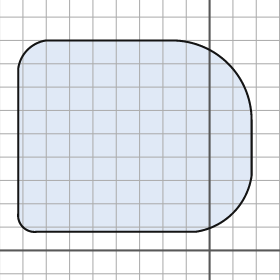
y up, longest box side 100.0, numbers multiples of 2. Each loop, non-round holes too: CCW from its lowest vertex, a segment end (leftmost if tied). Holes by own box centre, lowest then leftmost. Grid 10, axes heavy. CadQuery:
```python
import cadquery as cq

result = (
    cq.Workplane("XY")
    .moveTo(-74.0, 8.0)
    .lineTo(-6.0, 8.0)
    .threePointArc((10.0, 16.0), (18.0, 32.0))
    .lineTo(18.0, 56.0)
    .threePointArc((8.0, 80.0), (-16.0, 90.0))
    .lineTo(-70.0, 90.0)
    .threePointArc((-78.0, 86.0), (-82.0, 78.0))
    .lineTo(-82.0, 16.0)
    .threePointArc((-80.0, 10.0), (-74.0, 8.0))
    .close()
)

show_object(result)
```